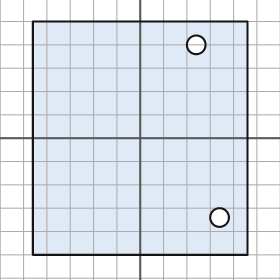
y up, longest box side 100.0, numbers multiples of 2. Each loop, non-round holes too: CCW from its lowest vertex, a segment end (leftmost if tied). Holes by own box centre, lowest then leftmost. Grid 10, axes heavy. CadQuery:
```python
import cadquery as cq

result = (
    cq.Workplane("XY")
    .moveTo(-46.0, -50.0)
    .lineTo(46.0, -50.0)
    .lineTo(46.0, 50.0)
    .lineTo(-46.0, 50.0)
    .close()
    .moveTo(34.0, -34.0)
    .circle(4.0)
    .moveTo(24.0, 40.0)
    .circle(4.0)
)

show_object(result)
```